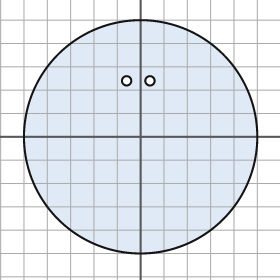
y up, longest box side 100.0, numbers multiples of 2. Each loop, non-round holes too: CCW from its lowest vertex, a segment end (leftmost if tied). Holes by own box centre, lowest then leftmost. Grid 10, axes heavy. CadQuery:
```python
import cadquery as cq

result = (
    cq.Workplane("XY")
    .moveTo(0.0, 0.0)
    .circle(50.0)
    .moveTo(-6.0, 24.0)
    .circle(2.0)
    .moveTo(4.0, 24.0)
    .circle(2.0)
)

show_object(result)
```